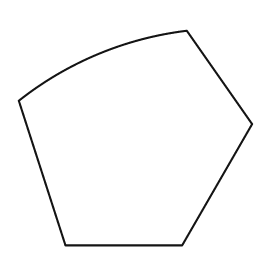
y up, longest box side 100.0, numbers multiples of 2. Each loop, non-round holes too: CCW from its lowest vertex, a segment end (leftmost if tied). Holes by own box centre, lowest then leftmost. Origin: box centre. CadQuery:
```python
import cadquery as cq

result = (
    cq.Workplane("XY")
    .moveTo(-30.0, -46.0)
    .lineTo(20.0, -46.0)
    .lineTo(50.0, 6.0)
    .lineTo(22.0, 46.0)
    .threePointArc((-16.0, 36.0), (-50.0, 16.0))
    .close()
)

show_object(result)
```